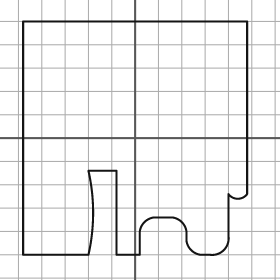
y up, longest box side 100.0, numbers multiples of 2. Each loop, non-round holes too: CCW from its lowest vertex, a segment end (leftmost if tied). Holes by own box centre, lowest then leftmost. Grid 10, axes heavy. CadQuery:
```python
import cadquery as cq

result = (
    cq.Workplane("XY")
    .moveTo(-48.0, -50.0)
    .lineTo(-20.0, -50.0)
    .threePointArc((-18.0, -32.0), (-20.0, -14.0))
    .lineTo(-8.0, -14.0)
    .lineTo(-8.0, -50.0)
    .lineTo(2.0, -50.0)
    .lineTo(2.0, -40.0)
    .threePointArc((4.0, -36.0), (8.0, -34.0))
    .lineTo(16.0, -34.0)
    .threePointArc((20.0, -36.0), (22.0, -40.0))
    .lineTo(22.0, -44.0)
    .threePointArc((24.0, -48.0), (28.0, -50.0))
    .lineTo(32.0, -50.0)
    .threePointArc((38.0, -48.0), (40.0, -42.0))
    .lineTo(40.0, -24.0)
    .threePointArc((44.0, -26.0), (48.0, -24.0))
    .lineTo(48.0, 50.0)
    .lineTo(-48.0, 50.0)
    .close()
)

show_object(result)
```